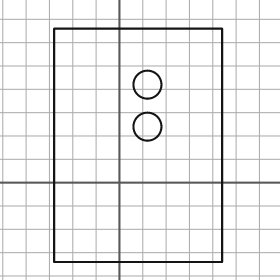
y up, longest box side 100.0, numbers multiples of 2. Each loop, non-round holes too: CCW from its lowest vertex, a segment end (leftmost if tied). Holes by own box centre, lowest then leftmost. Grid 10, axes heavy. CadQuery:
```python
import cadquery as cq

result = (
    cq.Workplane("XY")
    .moveTo(-28.0, -34.0)
    .lineTo(44.0, -34.0)
    .lineTo(44.0, 66.0)
    .lineTo(-28.0, 66.0)
    .close()
    .moveTo(12.0, 24.0)
    .circle(6.0)
    .moveTo(12.0, 42.0)
    .circle(6.0)
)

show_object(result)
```